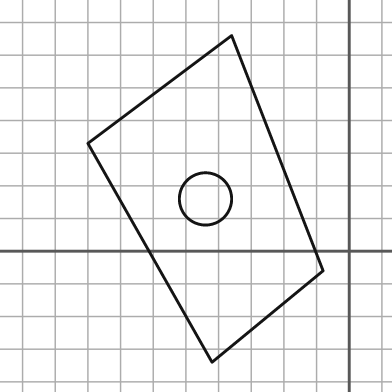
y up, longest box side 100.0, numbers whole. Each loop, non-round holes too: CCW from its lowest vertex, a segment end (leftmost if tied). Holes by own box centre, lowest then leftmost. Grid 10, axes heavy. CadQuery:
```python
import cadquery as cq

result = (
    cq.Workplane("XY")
    .moveTo(-42.0, -34.0)
    .lineTo(-8.0, -6.0)
    .lineTo(-36.0, 66.0)
    .lineTo(-80.0, 33.0)
    .close()
    .moveTo(-44.0, 16.0)
    .circle(8.0)
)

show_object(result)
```